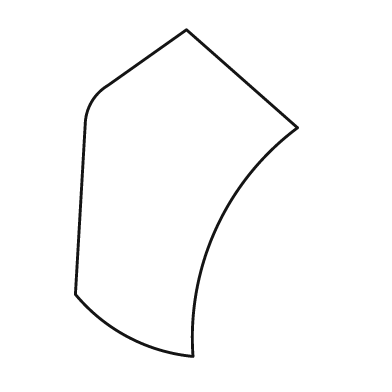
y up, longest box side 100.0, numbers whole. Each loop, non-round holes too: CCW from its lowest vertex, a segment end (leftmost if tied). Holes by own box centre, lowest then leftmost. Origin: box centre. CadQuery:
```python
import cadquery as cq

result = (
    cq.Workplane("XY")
    .moveTo(2.0, -50.0)
    .threePointArc((9.0, -11.0), (34.0, 20.0))
    .lineTo(0.0, 50.0)
    .lineTo(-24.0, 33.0)
    .threePointArc((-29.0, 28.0), (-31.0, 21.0))
    .lineTo(-34.0, -31.0)
    .threePointArc((-18.0, -44.0), (2.0, -50.0))
    .close()
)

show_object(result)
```